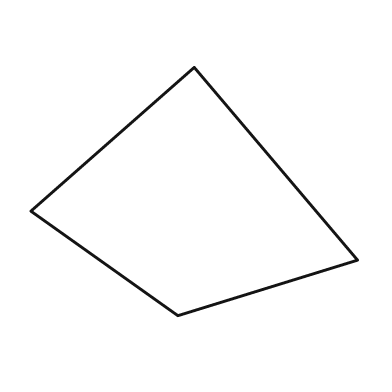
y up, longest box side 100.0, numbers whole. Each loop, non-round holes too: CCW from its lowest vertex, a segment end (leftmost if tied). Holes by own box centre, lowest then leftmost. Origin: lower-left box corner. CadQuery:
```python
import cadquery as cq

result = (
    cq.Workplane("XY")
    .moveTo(45.0, 0.0)
    .lineTo(100.0, 17.0)
    .lineTo(50.0, 76.0)
    .lineTo(0.0, 32.0)
    .close()
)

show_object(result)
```